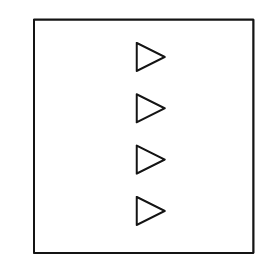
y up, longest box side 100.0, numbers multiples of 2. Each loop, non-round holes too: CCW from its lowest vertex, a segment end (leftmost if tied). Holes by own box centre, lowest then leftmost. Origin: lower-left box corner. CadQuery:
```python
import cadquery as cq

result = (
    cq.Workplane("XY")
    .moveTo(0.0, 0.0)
    .lineTo(94.0, 0.0)
    .lineTo(94.0, 100.0)
    .lineTo(0.0, 100.0)
    .close()
    .moveTo(44.0, 12.0)
    .lineTo(56.0, 18.0)
    .lineTo(44.0, 24.0)
    .close()
    .moveTo(44.0, 34.0)
    .lineTo(56.0, 40.0)
    .lineTo(44.0, 46.0)
    .close()
    .moveTo(44.0, 56.0)
    .lineTo(56.0, 62.0)
    .lineTo(44.0, 68.0)
    .close()
    .moveTo(44.0, 78.0)
    .lineTo(56.0, 84.0)
    .lineTo(44.0, 90.0)
    .close()
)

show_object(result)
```